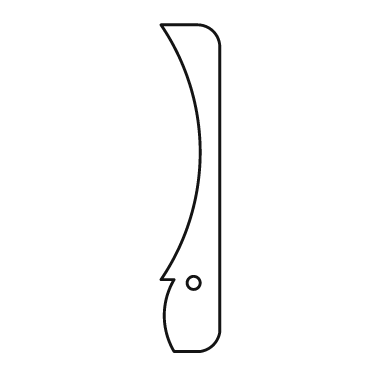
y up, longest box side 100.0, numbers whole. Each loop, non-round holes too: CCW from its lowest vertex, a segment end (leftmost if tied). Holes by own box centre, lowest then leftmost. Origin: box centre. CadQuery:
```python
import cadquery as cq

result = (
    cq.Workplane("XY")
    .moveTo(-5.0, -50.0)
    .lineTo(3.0, -50.0)
    .threePointArc((7.0, -48.0), (9.0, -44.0))
    .lineTo(9.0, 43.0)
    .threePointArc((7.0, 48.0), (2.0, 50.0))
    .lineTo(-9.0, 50.0)
    .threePointArc((3.0, 11.0), (-9.0, -28.0))
    .lineTo(-5.0, -28.0)
    .threePointArc((-8.0, -39.0), (-5.0, -50.0))
    .close()
    .moveTo(1.0, -29.0)
    .circle(2.0)
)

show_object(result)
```